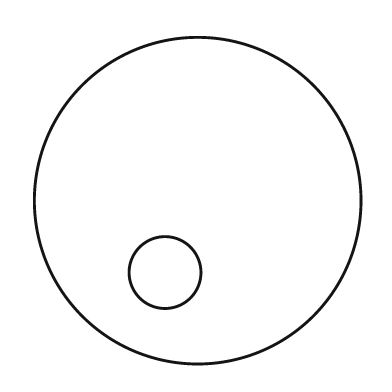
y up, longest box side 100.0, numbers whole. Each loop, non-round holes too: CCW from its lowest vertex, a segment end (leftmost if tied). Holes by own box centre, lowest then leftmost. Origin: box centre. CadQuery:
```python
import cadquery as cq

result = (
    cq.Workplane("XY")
    .moveTo(0.0, 0.0)
    .circle(50.0)
    .moveTo(-10.0, -22.0)
    .circle(11.0)
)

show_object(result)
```